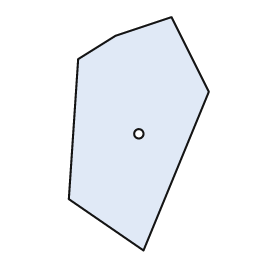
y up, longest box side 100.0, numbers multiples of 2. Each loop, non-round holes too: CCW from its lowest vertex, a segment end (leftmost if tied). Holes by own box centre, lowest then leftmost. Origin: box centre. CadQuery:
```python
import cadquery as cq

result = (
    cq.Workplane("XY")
    .moveTo(2.0, -50.0)
    .lineTo(30.0, 18.0)
    .lineTo(14.0, 50.0)
    .lineTo(-10.0, 42.0)
    .lineTo(-26.0, 32.0)
    .lineTo(-30.0, -28.0)
    .close()
    .moveTo(0.0, 0.0)
    .circle(2.0)
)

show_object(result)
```